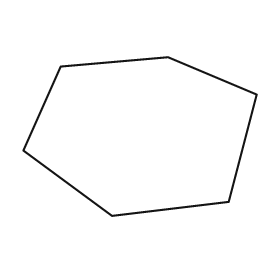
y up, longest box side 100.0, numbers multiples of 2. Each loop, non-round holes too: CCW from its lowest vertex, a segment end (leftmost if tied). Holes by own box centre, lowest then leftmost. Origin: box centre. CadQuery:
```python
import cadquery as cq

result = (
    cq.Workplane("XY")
    .moveTo(-12.0, -34.0)
    .lineTo(38.0, -28.0)
    .lineTo(50.0, 18.0)
    .lineTo(12.0, 34.0)
    .lineTo(-34.0, 30.0)
    .lineTo(-50.0, -6.0)
    .close()
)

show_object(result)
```